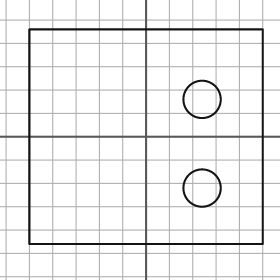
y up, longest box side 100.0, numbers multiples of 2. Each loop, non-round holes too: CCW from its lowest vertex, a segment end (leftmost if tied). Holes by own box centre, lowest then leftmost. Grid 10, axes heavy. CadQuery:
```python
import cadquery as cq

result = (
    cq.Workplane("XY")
    .moveTo(-50.0, -46.0)
    .lineTo(50.0, -46.0)
    .lineTo(50.0, 46.0)
    .lineTo(-50.0, 46.0)
    .close()
    .moveTo(24.0, -22.0)
    .circle(8.0)
    .moveTo(24.0, 16.0)
    .circle(8.0)
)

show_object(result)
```